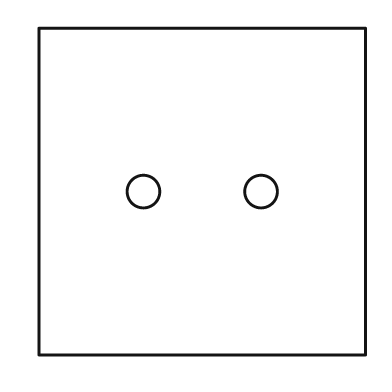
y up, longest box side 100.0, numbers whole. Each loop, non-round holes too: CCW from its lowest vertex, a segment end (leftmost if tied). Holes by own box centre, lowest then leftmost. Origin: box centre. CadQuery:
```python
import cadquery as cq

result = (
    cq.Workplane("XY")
    .moveTo(-50.0, -50.0)
    .lineTo(50.0, -50.0)
    .lineTo(50.0, 50.0)
    .lineTo(-50.0, 50.0)
    .close()
    .moveTo(-18.0, 0.0)
    .circle(5.0)
    .moveTo(18.0, 0.0)
    .circle(5.0)
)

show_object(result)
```